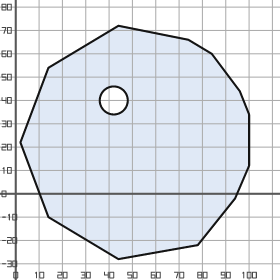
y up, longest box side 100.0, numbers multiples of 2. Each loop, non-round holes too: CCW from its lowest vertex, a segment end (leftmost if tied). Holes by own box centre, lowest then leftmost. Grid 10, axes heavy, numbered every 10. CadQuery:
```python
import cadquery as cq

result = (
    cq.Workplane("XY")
    .moveTo(44.0, -28.0)
    .lineTo(78.0, -22.0)
    .lineTo(94.0, -2.0)
    .lineTo(100.0, 12.0)
    .lineTo(100.0, 34.0)
    .lineTo(96.0, 44.0)
    .lineTo(84.0, 60.0)
    .lineTo(74.0, 66.0)
    .lineTo(44.0, 72.0)
    .lineTo(14.0, 54.0)
    .lineTo(2.0, 22.0)
    .lineTo(14.0, -10.0)
    .close()
    .moveTo(42.0, 40.0)
    .circle(6.0)
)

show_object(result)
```